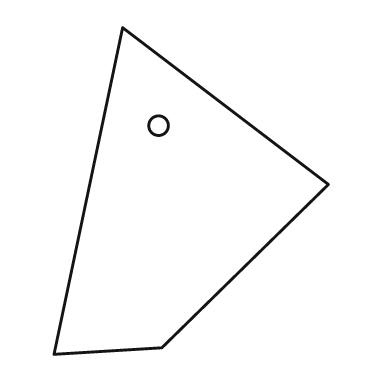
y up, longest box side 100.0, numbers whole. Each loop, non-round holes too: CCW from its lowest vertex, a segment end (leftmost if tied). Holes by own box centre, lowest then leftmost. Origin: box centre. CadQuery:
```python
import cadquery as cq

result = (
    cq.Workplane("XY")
    .moveTo(-42.0, -50.0)
    .lineTo(-9.0, -48.0)
    .lineTo(42.0, 2.0)
    .lineTo(-21.0, 50.0)
    .close()
    .moveTo(-10.0, 20.0)
    .circle(3.0)
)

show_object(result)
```